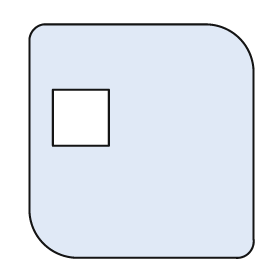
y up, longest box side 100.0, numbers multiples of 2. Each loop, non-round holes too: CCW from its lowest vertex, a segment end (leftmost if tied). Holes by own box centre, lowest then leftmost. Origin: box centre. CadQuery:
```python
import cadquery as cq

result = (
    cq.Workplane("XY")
    .moveTo(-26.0, -50.0)
    .lineTo(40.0, -50.0)
    .threePointArc((46.0, -48.0), (48.0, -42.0))
    .lineTo(48.0, 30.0)
    .threePointArc((42.0, 44.0), (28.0, 50.0))
    .lineTo(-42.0, 50.0)
    .threePointArc((-46.0, 48.0), (-48.0, 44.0))
    .lineTo(-48.0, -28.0)
    .threePointArc((-42.0, -44.0), (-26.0, -50.0))
    .close()
    .moveTo(-38.0, -2.0)
    .lineTo(-14.0, -2.0)
    .lineTo(-14.0, 22.0)
    .lineTo(-38.0, 22.0)
    .close()
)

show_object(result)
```